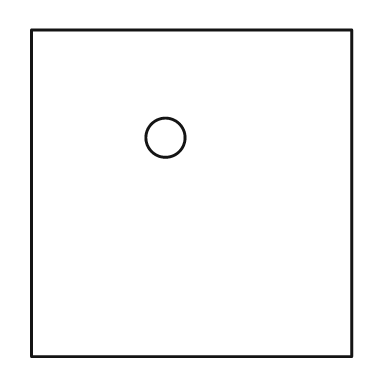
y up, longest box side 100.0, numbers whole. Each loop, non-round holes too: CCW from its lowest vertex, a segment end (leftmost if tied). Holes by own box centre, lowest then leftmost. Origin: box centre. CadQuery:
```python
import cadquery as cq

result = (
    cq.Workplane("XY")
    .moveTo(-49.0, -50.0)
    .lineTo(49.0, -50.0)
    .lineTo(49.0, 50.0)
    .lineTo(-49.0, 50.0)
    .close()
    .moveTo(-8.0, 17.0)
    .circle(6.0)
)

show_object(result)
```